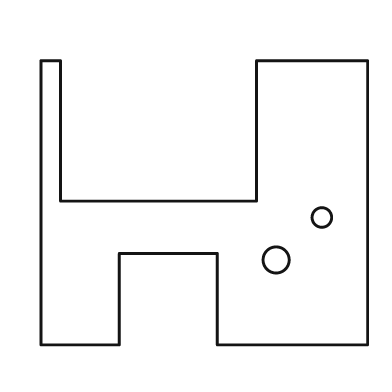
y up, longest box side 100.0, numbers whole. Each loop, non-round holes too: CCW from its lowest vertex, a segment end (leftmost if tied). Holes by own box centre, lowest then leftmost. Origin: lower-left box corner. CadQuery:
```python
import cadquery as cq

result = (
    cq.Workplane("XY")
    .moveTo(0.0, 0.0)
    .lineTo(24.0, 0.0)
    .lineTo(24.0, 28.0)
    .lineTo(54.0, 28.0)
    .lineTo(54.0, 0.0)
    .lineTo(100.0, 0.0)
    .lineTo(100.0, 87.0)
    .lineTo(66.0, 87.0)
    .lineTo(66.0, 44.0)
    .lineTo(6.0, 44.0)
    .lineTo(6.0, 87.0)
    .lineTo(0.0, 87.0)
    .close()
    .moveTo(72.0, 26.0)
    .circle(4.0)
    .moveTo(86.0, 39.0)
    .circle(3.0)
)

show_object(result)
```